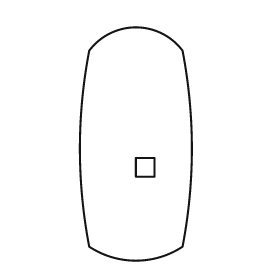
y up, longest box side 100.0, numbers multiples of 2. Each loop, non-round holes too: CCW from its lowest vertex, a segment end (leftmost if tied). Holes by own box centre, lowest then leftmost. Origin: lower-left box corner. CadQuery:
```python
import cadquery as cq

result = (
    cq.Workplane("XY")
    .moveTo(4.0, 6.0)
    .threePointArc((24.0, 0.0), (44.0, 6.0))
    .threePointArc((48.0, 48.0), (44.0, 90.0))
    .threePointArc((24.0, 100.0), (4.0, 90.0))
    .threePointArc((0.0, 48.0), (4.0, 6.0))
    .close()
    .moveTo(24.0, 36.0)
    .lineTo(32.0, 36.0)
    .lineTo(32.0, 44.0)
    .lineTo(24.0, 44.0)
    .close()
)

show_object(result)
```